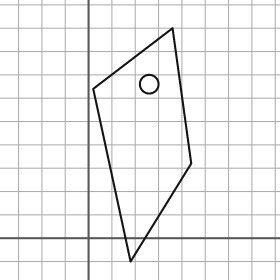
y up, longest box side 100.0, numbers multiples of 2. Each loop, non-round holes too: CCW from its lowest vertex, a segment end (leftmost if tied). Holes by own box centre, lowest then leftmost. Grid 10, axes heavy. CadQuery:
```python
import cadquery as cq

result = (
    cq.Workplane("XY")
    .moveTo(18.0, -10.0)
    .lineTo(44.0, 32.0)
    .lineTo(36.0, 90.0)
    .lineTo(2.0, 64.0)
    .close()
    .moveTo(26.0, 66.0)
    .circle(4.0)
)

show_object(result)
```